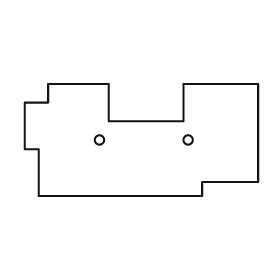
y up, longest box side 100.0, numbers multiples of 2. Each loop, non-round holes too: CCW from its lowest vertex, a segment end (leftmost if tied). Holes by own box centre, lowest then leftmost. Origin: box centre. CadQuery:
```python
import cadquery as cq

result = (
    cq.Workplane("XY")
    .moveTo(-44.0, -24.0)
    .lineTo(26.0, -24.0)
    .lineTo(26.0, -18.0)
    .lineTo(50.0, -18.0)
    .lineTo(50.0, 24.0)
    .lineTo(18.0, 24.0)
    .lineTo(18.0, 8.0)
    .lineTo(-14.0, 8.0)
    .lineTo(-14.0, 24.0)
    .lineTo(-40.0, 24.0)
    .lineTo(-40.0, 16.0)
    .lineTo(-50.0, 16.0)
    .lineTo(-50.0, -4.0)
    .lineTo(-44.0, -4.0)
    .close()
    .moveTo(-18.0, 0.0)
    .circle(2.0)
    .moveTo(20.0, 0.0)
    .circle(2.0)
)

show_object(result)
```